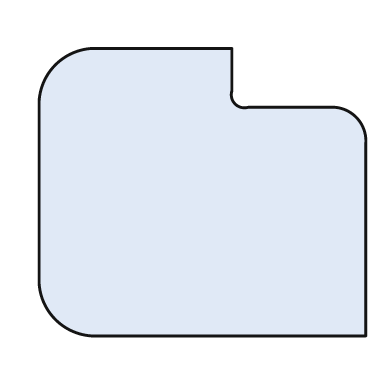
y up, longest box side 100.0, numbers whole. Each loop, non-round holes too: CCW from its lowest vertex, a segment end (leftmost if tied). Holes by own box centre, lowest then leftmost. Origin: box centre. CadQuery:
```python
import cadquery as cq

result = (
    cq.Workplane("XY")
    .moveTo(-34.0, -44.0)
    .lineTo(50.0, -44.0)
    .lineTo(50.0, 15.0)
    .threePointArc((47.0, 23.0), (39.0, 26.0))
    .lineTo(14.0, 26.0)
    .threePointArc((10.0, 27.0), (9.0, 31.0))
    .lineTo(9.0, 44.0)
    .lineTo(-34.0, 44.0)
    .threePointArc((-45.0, 39.0), (-50.0, 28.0))
    .lineTo(-50.0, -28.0)
    .threePointArc((-45.0, -39.0), (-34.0, -44.0))
    .close()
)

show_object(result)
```